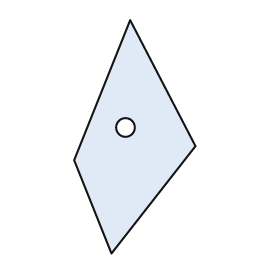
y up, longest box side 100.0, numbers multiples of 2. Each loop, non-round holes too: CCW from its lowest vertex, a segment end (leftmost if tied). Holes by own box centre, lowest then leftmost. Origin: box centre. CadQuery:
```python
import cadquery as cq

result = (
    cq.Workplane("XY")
    .moveTo(-10.0, -50.0)
    .lineTo(26.0, -4.0)
    .lineTo(-2.0, 50.0)
    .lineTo(-26.0, -10.0)
    .close()
    .moveTo(-4.0, 4.0)
    .circle(4.0)
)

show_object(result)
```